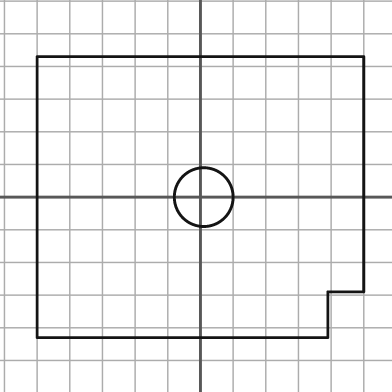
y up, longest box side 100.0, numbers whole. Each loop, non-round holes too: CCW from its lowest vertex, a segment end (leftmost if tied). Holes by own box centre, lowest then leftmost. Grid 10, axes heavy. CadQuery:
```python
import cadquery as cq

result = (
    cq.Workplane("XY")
    .moveTo(-50.0, -43.0)
    .lineTo(39.0, -43.0)
    .lineTo(39.0, -29.0)
    .lineTo(50.0, -29.0)
    .lineTo(50.0, 43.0)
    .lineTo(-50.0, 43.0)
    .close()
    .moveTo(1.0, 0.0)
    .circle(9.0)
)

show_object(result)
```